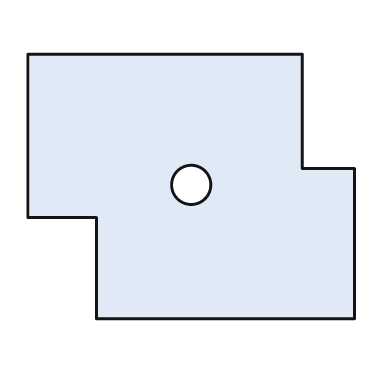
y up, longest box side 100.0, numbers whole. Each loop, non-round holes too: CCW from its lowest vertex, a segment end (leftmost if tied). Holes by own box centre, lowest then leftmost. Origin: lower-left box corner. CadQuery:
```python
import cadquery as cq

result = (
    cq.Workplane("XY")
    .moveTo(21.0, 0.0)
    .lineTo(100.0, 0.0)
    .lineTo(100.0, 46.0)
    .lineTo(84.0, 46.0)
    .lineTo(84.0, 81.0)
    .lineTo(0.0, 81.0)
    .lineTo(0.0, 31.0)
    .lineTo(21.0, 31.0)
    .close()
    .moveTo(50.0, 41.0)
    .circle(6.0)
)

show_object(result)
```